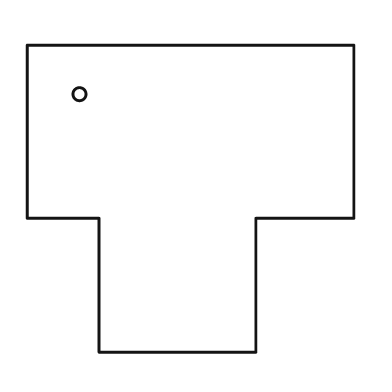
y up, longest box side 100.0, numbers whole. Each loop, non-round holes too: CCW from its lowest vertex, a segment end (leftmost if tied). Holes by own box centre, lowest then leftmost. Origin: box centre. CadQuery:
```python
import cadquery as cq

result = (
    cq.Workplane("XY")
    .moveTo(-28.0, -47.0)
    .lineTo(20.0, -47.0)
    .lineTo(20.0, -6.0)
    .lineTo(50.0, -6.0)
    .lineTo(50.0, 47.0)
    .lineTo(-50.0, 47.0)
    .lineTo(-50.0, -6.0)
    .lineTo(-28.0, -6.0)
    .close()
    .moveTo(-34.0, 32.0)
    .circle(2.0)
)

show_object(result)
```